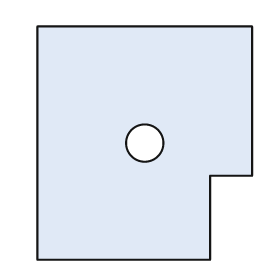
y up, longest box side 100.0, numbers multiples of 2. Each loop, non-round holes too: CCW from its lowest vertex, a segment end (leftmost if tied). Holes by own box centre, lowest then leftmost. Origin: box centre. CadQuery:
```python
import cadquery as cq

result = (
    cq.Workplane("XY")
    .moveTo(-46.0, -50.0)
    .lineTo(28.0, -50.0)
    .lineTo(28.0, -14.0)
    .lineTo(46.0, -14.0)
    .lineTo(46.0, 50.0)
    .lineTo(-46.0, 50.0)
    .close()
    .moveTo(0.0, 0.0)
    .circle(8.0)
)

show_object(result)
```